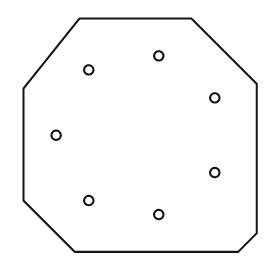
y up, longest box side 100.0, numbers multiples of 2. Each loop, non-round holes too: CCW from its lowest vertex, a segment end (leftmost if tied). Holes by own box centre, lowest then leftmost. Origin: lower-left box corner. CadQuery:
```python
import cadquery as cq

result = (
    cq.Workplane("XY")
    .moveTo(22.0, 0.0)
    .lineTo(92.0, 0.0)
    .lineTo(100.0, 8.0)
    .lineTo(100.0, 72.0)
    .lineTo(72.0, 100.0)
    .lineTo(24.0, 100.0)
    .lineTo(0.0, 70.0)
    .lineTo(0.0, 22.0)
    .close()
    .moveTo(58.0, 16.0)
    .circle(2.0)
    .moveTo(28.0, 22.0)
    .circle(2.0)
    .moveTo(82.0, 34.0)
    .circle(2.0)
    .moveTo(14.0, 50.0)
    .circle(2.0)
    .moveTo(82.0, 66.0)
    .circle(2.0)
    .moveTo(28.0, 78.0)
    .circle(2.0)
    .moveTo(58.0, 84.0)
    .circle(2.0)
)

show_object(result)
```